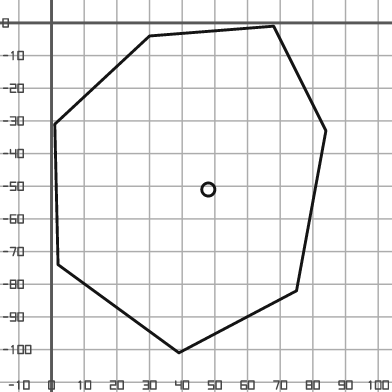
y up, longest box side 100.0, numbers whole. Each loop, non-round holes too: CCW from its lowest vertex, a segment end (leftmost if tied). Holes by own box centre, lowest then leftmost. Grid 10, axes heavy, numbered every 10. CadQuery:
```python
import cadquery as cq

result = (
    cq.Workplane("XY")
    .moveTo(39.0, -101.0)
    .lineTo(75.0, -82.0)
    .lineTo(84.0, -33.0)
    .lineTo(68.0, -1.0)
    .lineTo(30.0, -4.0)
    .lineTo(1.0, -31.0)
    .lineTo(2.0, -74.0)
    .close()
    .moveTo(48.0, -51.0)
    .circle(2.0)
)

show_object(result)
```